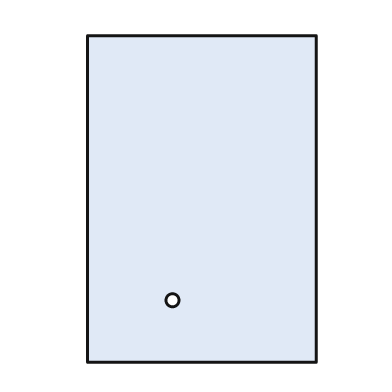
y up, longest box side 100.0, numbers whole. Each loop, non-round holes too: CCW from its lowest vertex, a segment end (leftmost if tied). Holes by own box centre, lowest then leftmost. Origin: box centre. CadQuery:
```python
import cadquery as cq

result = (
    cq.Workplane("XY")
    .moveTo(-35.0, -50.0)
    .lineTo(35.0, -50.0)
    .lineTo(35.0, 50.0)
    .lineTo(-35.0, 50.0)
    .close()
    .moveTo(-9.0, -31.0)
    .circle(2.0)
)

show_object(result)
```